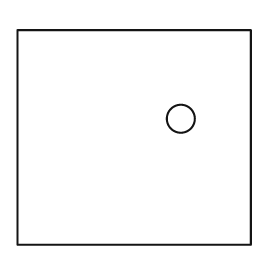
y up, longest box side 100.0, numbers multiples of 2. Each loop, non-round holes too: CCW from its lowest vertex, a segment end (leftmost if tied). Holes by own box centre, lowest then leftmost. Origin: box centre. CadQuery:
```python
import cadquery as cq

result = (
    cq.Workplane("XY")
    .moveTo(-50.0, -46.0)
    .lineTo(50.0, -46.0)
    .lineTo(50.0, 46.0)
    .lineTo(-50.0, 46.0)
    .close()
    .moveTo(20.0, 8.0)
    .circle(6.0)
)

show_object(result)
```